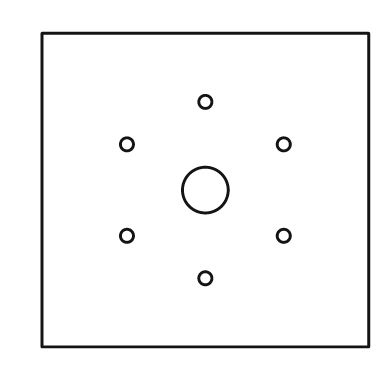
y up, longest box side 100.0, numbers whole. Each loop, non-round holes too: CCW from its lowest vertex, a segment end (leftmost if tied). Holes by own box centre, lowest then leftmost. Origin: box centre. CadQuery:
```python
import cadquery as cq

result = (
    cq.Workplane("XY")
    .moveTo(-50.0, -48.0)
    .lineTo(50.0, -48.0)
    .lineTo(50.0, 48.0)
    .lineTo(-50.0, 48.0)
    .close()
    .moveTo(0.0, -27.0)
    .circle(2.0)
    .moveTo(-24.0, -14.0)
    .circle(2.0)
    .moveTo(24.0, -14.0)
    .circle(2.0)
    .moveTo(0.0, 0.0)
    .circle(7.0)
    .moveTo(-24.0, 14.0)
    .circle(2.0)
    .moveTo(24.0, 14.0)
    .circle(2.0)
    .moveTo(0.0, 27.0)
    .circle(2.0)
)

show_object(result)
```